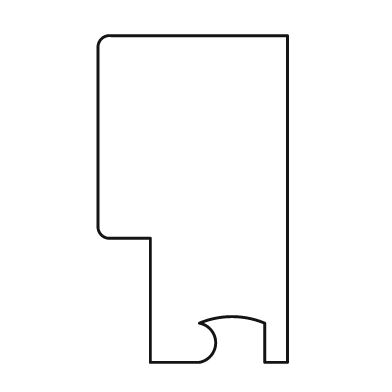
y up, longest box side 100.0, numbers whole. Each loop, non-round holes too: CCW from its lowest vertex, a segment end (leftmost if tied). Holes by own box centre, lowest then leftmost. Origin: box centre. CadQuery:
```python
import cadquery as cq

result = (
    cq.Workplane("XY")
    .moveTo(-13.0, -50.0)
    .lineTo(2.0, -50.0)
    .threePointArc((7.0, -44.0), (2.0, -38.0))
    .threePointArc((12.0, -36.0), (22.0, -38.0))
    .lineTo(22.0, -50.0)
    .lineTo(29.0, -50.0)
    .lineTo(29.0, 50.0)
    .lineTo(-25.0, 50.0)
    .threePointArc((-28.0, 49.0), (-29.0, 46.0))
    .lineTo(-29.0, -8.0)
    .threePointArc((-28.0, -11.0), (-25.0, -12.0))
    .lineTo(-13.0, -12.0)
    .close()
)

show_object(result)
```